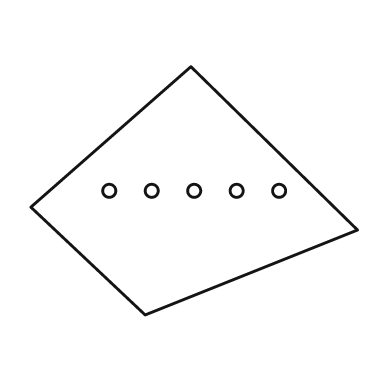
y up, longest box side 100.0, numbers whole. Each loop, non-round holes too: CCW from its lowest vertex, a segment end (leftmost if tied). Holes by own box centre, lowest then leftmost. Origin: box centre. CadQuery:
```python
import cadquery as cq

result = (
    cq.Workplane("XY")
    .moveTo(-15.0, -38.0)
    .lineTo(50.0, -12.0)
    .lineTo(-1.0, 38.0)
    .lineTo(-50.0, -5.0)
    .close()
    .moveTo(-26.0, 0.0)
    .circle(2.0)
    .moveTo(-13.0, 0.0)
    .circle(2.0)
    .moveTo(0.0, 0.0)
    .circle(2.0)
    .moveTo(13.0, 0.0)
    .circle(2.0)
    .moveTo(26.0, 0.0)
    .circle(2.0)
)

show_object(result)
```